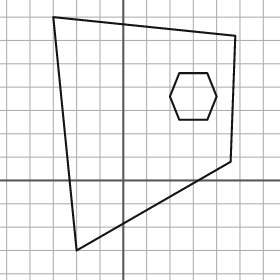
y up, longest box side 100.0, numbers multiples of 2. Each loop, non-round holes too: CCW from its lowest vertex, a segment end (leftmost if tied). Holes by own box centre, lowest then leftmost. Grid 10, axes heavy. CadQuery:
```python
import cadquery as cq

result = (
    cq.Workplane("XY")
    .moveTo(-20.0, -30.0)
    .lineTo(46.0, 8.0)
    .lineTo(48.0, 62.0)
    .lineTo(-30.0, 70.0)
    .close()
    .moveTo(24.0, 26.0)
    .lineTo(36.0, 26.0)
    .lineTo(40.0, 36.0)
    .lineTo(36.0, 46.0)
    .lineTo(24.0, 46.0)
    .lineTo(20.0, 36.0)
    .close()
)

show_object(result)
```